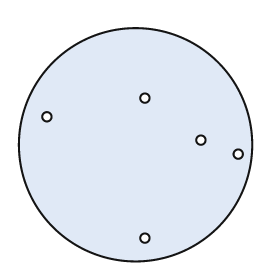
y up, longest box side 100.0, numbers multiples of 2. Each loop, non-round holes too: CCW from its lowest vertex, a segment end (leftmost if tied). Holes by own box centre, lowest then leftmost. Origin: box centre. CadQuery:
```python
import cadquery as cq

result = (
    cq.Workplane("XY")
    .moveTo(0.0, 0.0)
    .circle(50.0)
    .moveTo(4.0, -40.0)
    .circle(2.0)
    .moveTo(44.0, -4.0)
    .circle(2.0)
    .moveTo(28.0, 2.0)
    .circle(2.0)
    .moveTo(-38.0, 12.0)
    .circle(2.0)
    .moveTo(4.0, 20.0)
    .circle(2.0)
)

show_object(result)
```